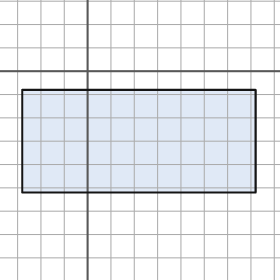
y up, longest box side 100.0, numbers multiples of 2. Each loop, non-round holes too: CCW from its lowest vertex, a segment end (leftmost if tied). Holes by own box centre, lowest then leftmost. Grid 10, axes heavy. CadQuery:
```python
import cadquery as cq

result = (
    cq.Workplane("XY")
    .moveTo(-28.0, -52.0)
    .lineTo(72.0, -52.0)
    .lineTo(72.0, -8.0)
    .lineTo(-28.0, -8.0)
    .close()
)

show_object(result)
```